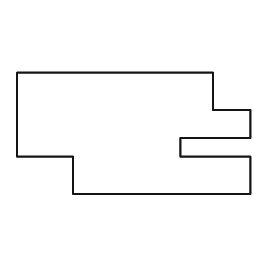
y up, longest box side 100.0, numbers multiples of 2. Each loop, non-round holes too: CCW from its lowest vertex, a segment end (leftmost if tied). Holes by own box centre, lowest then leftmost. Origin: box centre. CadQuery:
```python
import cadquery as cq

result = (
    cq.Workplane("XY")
    .moveTo(-26.0, -26.0)
    .lineTo(50.0, -26.0)
    .lineTo(50.0, -10.0)
    .lineTo(20.0, -10.0)
    .lineTo(20.0, -2.0)
    .lineTo(50.0, -2.0)
    .lineTo(50.0, 10.0)
    .lineTo(34.0, 10.0)
    .lineTo(34.0, 26.0)
    .lineTo(-50.0, 26.0)
    .lineTo(-50.0, -10.0)
    .lineTo(-26.0, -10.0)
    .close()
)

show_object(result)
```